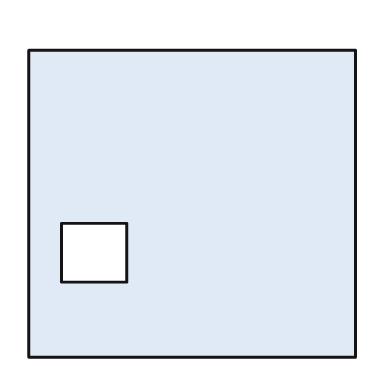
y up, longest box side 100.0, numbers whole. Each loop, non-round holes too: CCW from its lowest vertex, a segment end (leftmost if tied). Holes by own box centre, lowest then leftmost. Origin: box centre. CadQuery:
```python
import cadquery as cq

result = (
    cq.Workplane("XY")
    .moveTo(-50.0, -47.0)
    .lineTo(50.0, -47.0)
    .lineTo(50.0, 47.0)
    .lineTo(-50.0, 47.0)
    .close()
    .moveTo(-40.0, -24.0)
    .lineTo(-20.0, -24.0)
    .lineTo(-20.0, -6.0)
    .lineTo(-40.0, -6.0)
    .close()
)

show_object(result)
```